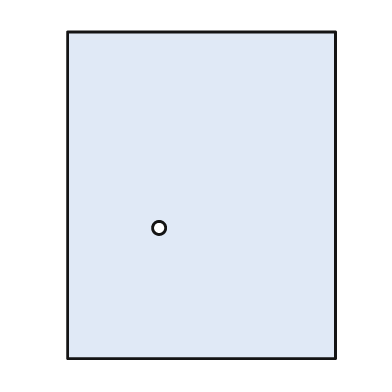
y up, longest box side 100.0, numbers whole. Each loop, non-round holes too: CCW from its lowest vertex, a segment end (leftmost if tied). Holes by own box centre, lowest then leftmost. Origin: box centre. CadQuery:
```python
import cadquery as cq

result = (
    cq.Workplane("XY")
    .moveTo(-41.0, -50.0)
    .lineTo(41.0, -50.0)
    .lineTo(41.0, 50.0)
    .lineTo(-41.0, 50.0)
    .close()
    .moveTo(-13.0, -10.0)
    .circle(2.0)
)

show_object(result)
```